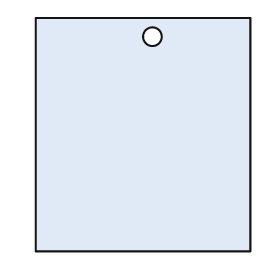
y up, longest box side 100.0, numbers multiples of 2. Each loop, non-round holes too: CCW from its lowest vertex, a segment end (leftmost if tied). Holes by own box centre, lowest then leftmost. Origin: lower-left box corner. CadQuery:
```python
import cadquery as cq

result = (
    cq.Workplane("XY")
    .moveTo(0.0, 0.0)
    .lineTo(92.0, 0.0)
    .lineTo(92.0, 100.0)
    .lineTo(0.0, 100.0)
    .close()
    .moveTo(50.0, 92.0)
    .circle(4.0)
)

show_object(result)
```